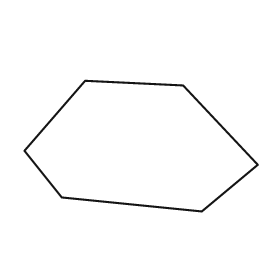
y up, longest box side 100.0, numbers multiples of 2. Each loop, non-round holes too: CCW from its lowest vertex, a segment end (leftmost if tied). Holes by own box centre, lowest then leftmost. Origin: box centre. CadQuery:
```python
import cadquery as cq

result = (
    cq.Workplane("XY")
    .moveTo(26.0, -28.0)
    .lineTo(50.0, -8.0)
    .lineTo(18.0, 26.0)
    .lineTo(-24.0, 28.0)
    .lineTo(-50.0, -2.0)
    .lineTo(-34.0, -22.0)
    .close()
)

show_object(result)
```